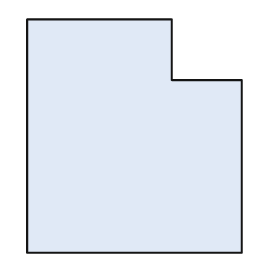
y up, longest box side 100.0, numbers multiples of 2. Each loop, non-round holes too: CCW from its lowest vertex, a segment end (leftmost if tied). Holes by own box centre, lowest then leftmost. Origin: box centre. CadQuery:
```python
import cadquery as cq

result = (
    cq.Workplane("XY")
    .moveTo(-46.0, -50.0)
    .lineTo(46.0, -50.0)
    .lineTo(46.0, 24.0)
    .lineTo(16.0, 24.0)
    .lineTo(16.0, 50.0)
    .lineTo(-46.0, 50.0)
    .close()
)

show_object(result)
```